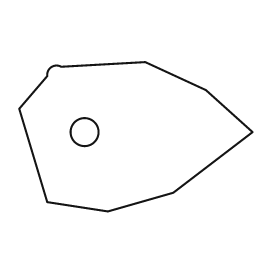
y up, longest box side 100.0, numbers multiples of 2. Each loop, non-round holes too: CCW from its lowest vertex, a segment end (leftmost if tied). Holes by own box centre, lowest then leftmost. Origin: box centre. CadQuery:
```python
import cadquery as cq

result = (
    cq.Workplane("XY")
    .moveTo(-12.0, -32.0)
    .lineTo(16.0, -24.0)
    .lineTo(50.0, 2.0)
    .lineTo(30.0, 20.0)
    .lineTo(4.0, 32.0)
    .lineTo(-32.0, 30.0)
    .threePointArc((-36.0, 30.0), (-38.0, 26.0))
    .lineTo(-50.0, 12.0)
    .lineTo(-38.0, -28.0)
    .close()
    .moveTo(-22.0, 2.0)
    .circle(6.0)
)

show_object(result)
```